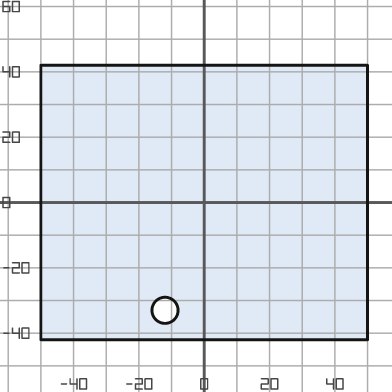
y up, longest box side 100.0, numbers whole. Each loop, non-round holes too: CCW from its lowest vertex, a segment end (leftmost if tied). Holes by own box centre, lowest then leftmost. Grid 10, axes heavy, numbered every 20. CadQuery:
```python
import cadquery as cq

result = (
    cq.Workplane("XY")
    .moveTo(-50.0, -42.0)
    .lineTo(50.0, -42.0)
    .lineTo(50.0, 42.0)
    .lineTo(-50.0, 42.0)
    .close()
    .moveTo(-12.0, -33.0)
    .circle(4.0)
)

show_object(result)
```